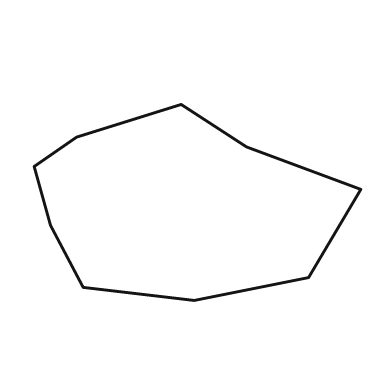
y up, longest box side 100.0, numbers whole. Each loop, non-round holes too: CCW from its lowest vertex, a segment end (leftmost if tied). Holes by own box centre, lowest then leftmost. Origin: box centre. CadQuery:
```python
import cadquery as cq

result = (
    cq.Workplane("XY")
    .moveTo(-1.0, -30.0)
    .lineTo(34.0, -23.0)
    .lineTo(50.0, 4.0)
    .lineTo(15.0, 17.0)
    .lineTo(-5.0, 30.0)
    .lineTo(-37.0, 20.0)
    .lineTo(-50.0, 11.0)
    .lineTo(-45.0, -7.0)
    .lineTo(-35.0, -26.0)
    .close()
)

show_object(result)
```